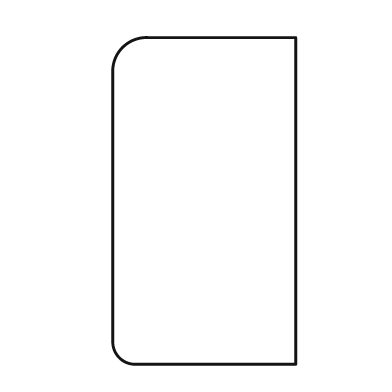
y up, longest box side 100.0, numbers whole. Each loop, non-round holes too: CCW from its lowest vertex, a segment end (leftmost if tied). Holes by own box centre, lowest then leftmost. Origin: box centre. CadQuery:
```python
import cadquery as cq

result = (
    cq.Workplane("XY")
    .moveTo(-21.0, -50.0)
    .lineTo(28.0, -50.0)
    .lineTo(28.0, 50.0)
    .lineTo(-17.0, 50.0)
    .threePointArc((-25.0, 47.0), (-28.0, 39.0))
    .lineTo(-28.0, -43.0)
    .threePointArc((-26.0, -48.0), (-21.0, -50.0))
    .close()
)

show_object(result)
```